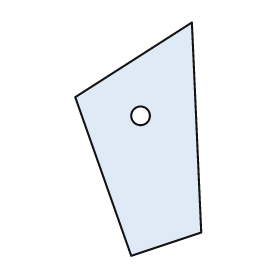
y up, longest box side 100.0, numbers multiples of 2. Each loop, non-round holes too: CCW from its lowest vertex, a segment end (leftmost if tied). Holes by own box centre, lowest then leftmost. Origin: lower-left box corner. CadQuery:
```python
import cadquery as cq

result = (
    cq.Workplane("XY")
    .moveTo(24.0, 0.0)
    .lineTo(54.0, 10.0)
    .lineTo(50.0, 100.0)
    .lineTo(0.0, 68.0)
    .close()
    .moveTo(28.0, 60.0)
    .circle(4.0)
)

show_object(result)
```